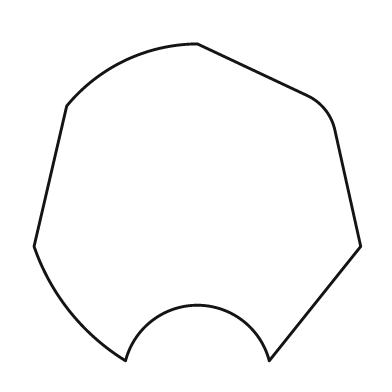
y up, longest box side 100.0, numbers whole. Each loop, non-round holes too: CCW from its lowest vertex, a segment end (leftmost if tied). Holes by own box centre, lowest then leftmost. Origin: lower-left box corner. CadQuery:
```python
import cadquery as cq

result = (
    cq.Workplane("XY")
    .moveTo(28.0, 0.0)
    .threePointArc((50.0, 17.0), (72.0, 0.0))
    .lineTo(100.0, 35.0)
    .lineTo(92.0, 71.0)
    .threePointArc((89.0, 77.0), (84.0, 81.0))
    .lineTo(50.0, 97.0)
    .threePointArc((28.0, 92.0), (10.0, 78.0))
    .lineTo(0.0, 35.0)
    .threePointArc((11.0, 15.0), (28.0, 0.0))
    .close()
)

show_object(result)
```